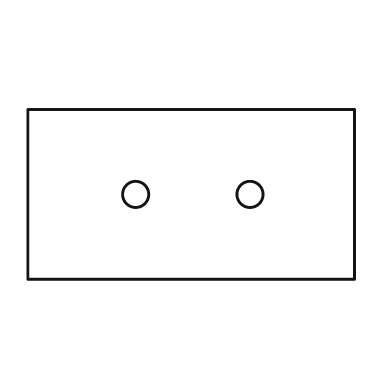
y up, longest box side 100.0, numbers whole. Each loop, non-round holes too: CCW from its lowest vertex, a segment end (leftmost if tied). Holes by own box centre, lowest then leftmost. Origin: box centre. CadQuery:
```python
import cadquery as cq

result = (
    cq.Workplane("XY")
    .moveTo(-50.0, -26.0)
    .lineTo(50.0, -26.0)
    .lineTo(50.0, 26.0)
    .lineTo(-50.0, 26.0)
    .close()
    .moveTo(-17.0, 0.0)
    .circle(4.0)
    .moveTo(18.0, 0.0)
    .circle(4.0)
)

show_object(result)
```